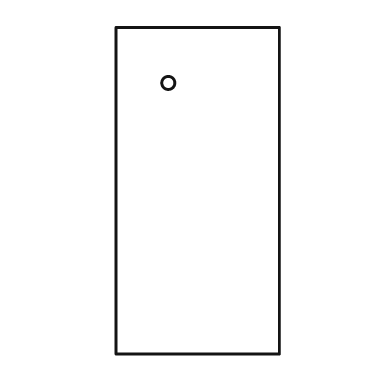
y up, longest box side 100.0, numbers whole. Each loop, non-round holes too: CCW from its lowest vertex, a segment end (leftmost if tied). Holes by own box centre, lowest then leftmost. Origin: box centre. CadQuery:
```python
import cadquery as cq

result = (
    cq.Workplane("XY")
    .moveTo(-25.0, -50.0)
    .lineTo(25.0, -50.0)
    .lineTo(25.0, 50.0)
    .lineTo(-25.0, 50.0)
    .close()
    .moveTo(-9.0, 33.0)
    .circle(2.0)
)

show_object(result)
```